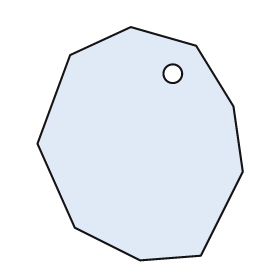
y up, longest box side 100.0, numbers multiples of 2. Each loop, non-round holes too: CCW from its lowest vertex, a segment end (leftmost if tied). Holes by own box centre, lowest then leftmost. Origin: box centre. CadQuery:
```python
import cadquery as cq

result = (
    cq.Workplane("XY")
    .moveTo(0.0, -50.0)
    .lineTo(26.0, -48.0)
    .lineTo(44.0, -12.0)
    .lineTo(40.0, 16.0)
    .lineTo(24.0, 42.0)
    .lineTo(-4.0, 50.0)
    .lineTo(-30.0, 38.0)
    .lineTo(-44.0, 0.0)
    .lineTo(-28.0, -36.0)
    .close()
    .moveTo(14.0, 30.0)
    .circle(4.0)
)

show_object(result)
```